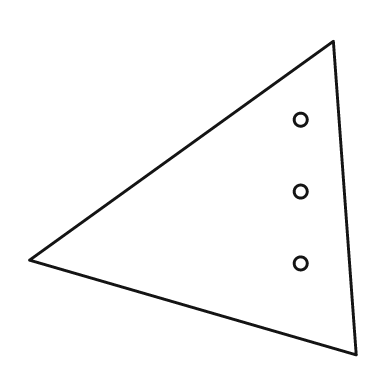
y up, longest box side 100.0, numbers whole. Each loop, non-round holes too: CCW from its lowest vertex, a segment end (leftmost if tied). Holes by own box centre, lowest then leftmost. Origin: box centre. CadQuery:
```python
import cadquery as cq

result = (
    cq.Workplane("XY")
    .moveTo(50.0, -48.0)
    .lineTo(43.0, 48.0)
    .lineTo(-50.0, -19.0)
    .close()
    .moveTo(33.0, -20.0)
    .circle(2.0)
    .moveTo(33.0, 2.0)
    .circle(2.0)
    .moveTo(33.0, 24.0)
    .circle(2.0)
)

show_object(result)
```